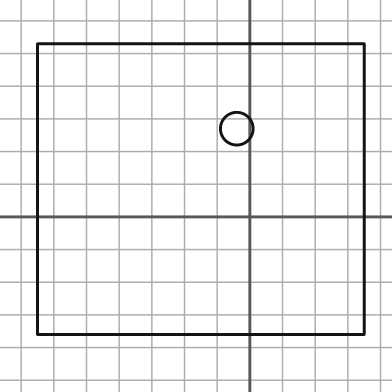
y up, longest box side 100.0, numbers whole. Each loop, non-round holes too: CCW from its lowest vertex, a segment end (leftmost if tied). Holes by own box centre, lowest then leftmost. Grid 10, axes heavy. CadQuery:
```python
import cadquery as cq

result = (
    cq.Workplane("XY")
    .moveTo(-65.0, -36.0)
    .lineTo(35.0, -36.0)
    .lineTo(35.0, 53.0)
    .lineTo(-65.0, 53.0)
    .close()
    .moveTo(-4.0, 27.0)
    .circle(5.0)
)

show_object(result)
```